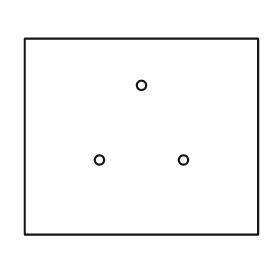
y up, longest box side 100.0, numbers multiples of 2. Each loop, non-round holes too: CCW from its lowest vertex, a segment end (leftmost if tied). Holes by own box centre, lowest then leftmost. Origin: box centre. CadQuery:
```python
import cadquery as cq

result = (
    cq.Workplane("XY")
    .moveTo(-50.0, -42.0)
    .lineTo(50.0, -42.0)
    .lineTo(50.0, 42.0)
    .lineTo(-50.0, 42.0)
    .close()
    .moveTo(-18.0, -10.0)
    .circle(2.0)
    .moveTo(18.0, -10.0)
    .circle(2.0)
    .moveTo(0.0, 22.0)
    .circle(2.0)
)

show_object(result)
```